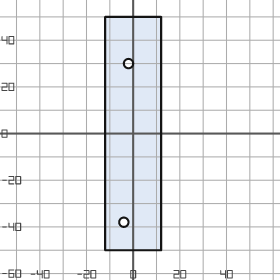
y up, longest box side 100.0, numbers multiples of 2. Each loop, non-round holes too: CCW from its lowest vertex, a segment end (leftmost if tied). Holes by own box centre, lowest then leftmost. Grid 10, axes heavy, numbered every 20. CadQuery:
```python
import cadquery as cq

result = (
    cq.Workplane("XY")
    .moveTo(-12.0, -50.0)
    .lineTo(12.0, -50.0)
    .lineTo(12.0, 50.0)
    .lineTo(-12.0, 50.0)
    .close()
    .moveTo(-4.0, -38.0)
    .circle(2.0)
    .moveTo(-2.0, 30.0)
    .circle(2.0)
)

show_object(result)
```